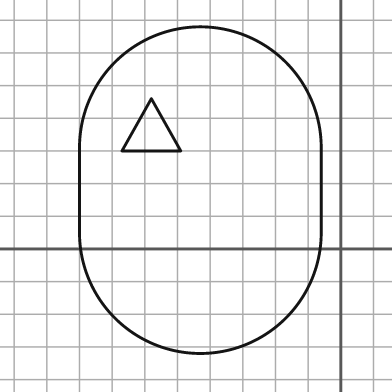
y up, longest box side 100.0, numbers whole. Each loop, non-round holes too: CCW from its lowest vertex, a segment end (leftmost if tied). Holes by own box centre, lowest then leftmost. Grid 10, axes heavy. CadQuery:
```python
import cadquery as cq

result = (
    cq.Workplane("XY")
    .moveTo(-80.0, 5.0)
    .threePointArc((-43.0, -32.0), (-6.0, 5.0))
    .lineTo(-6.0, 31.0)
    .threePointArc((-43.0, 68.0), (-80.0, 31.0))
    .close()
    .moveTo(-67.0, 30.0)
    .lineTo(-49.0, 30.0)
    .lineTo(-58.0, 46.0)
    .close()
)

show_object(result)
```